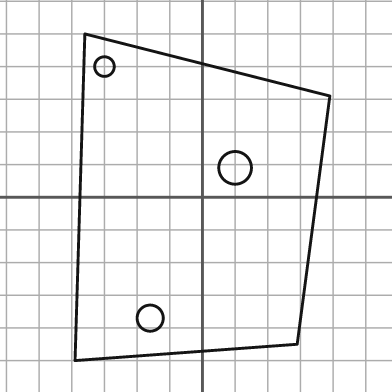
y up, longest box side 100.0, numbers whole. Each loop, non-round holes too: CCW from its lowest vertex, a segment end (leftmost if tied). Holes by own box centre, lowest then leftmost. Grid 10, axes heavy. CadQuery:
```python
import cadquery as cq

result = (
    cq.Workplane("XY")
    .moveTo(-39.0, -50.0)
    .lineTo(29.0, -45.0)
    .lineTo(39.0, 31.0)
    .lineTo(-36.0, 50.0)
    .close()
    .moveTo(-16.0, -37.0)
    .circle(4.0)
    .moveTo(10.0, 9.0)
    .circle(5.0)
    .moveTo(-30.0, 40.0)
    .circle(3.0)
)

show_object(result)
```